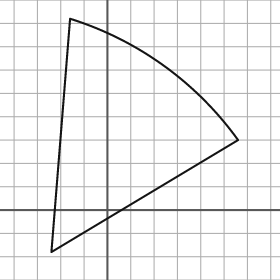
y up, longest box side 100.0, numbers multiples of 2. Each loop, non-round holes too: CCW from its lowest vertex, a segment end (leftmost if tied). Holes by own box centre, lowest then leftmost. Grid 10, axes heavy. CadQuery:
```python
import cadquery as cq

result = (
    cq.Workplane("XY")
    .moveTo(-24.0, -18.0)
    .lineTo(56.0, 30.0)
    .threePointArc((24.0, 62.0), (-16.0, 82.0))
    .close()
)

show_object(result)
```